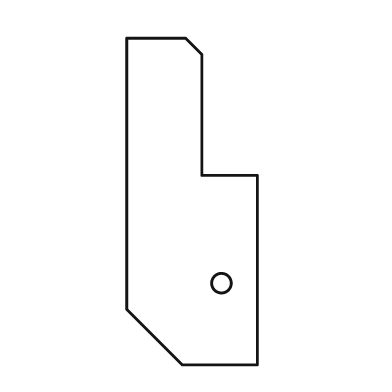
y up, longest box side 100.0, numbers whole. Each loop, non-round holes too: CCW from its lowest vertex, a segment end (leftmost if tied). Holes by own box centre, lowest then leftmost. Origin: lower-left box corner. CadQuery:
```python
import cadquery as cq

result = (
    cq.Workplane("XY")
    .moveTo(17.0, 0.0)
    .lineTo(40.0, 0.0)
    .lineTo(40.0, 58.0)
    .lineTo(23.0, 58.0)
    .lineTo(23.0, 95.0)
    .lineTo(18.0, 100.0)
    .lineTo(0.0, 100.0)
    .lineTo(0.0, 17.0)
    .close()
    .moveTo(29.0, 25.0)
    .circle(3.0)
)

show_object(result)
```